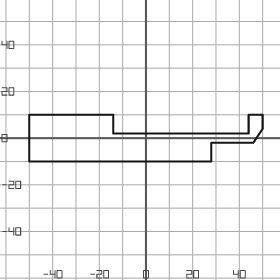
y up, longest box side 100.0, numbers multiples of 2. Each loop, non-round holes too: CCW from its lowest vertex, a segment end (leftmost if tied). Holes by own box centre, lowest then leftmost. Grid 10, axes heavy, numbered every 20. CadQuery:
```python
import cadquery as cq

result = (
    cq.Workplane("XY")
    .moveTo(-50.0, -10.0)
    .lineTo(28.0, -10.0)
    .lineTo(28.0, -2.0)
    .lineTo(46.0, -2.0)
    .lineTo(50.0, 4.0)
    .lineTo(50.0, 10.0)
    .lineTo(44.0, 10.0)
    .lineTo(44.0, 2.0)
    .lineTo(-14.0, 2.0)
    .lineTo(-14.0, 10.0)
    .lineTo(-50.0, 10.0)
    .close()
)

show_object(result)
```